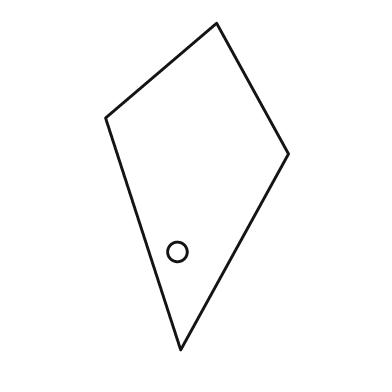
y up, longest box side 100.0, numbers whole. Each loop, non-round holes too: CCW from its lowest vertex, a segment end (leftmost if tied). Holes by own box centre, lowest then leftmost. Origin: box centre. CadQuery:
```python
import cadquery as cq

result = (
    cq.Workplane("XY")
    .moveTo(-5.0, -50.0)
    .lineTo(28.0, 10.0)
    .lineTo(6.0, 50.0)
    .lineTo(-28.0, 21.0)
    .close()
    .moveTo(-6.0, -20.0)
    .circle(3.0)
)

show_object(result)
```